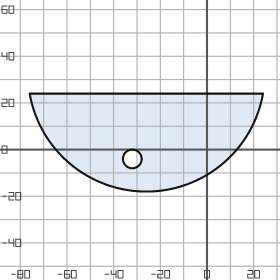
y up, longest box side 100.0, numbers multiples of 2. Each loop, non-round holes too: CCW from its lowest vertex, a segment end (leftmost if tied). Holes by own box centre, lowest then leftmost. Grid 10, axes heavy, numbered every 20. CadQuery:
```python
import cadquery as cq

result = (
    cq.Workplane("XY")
    .moveTo(-76.0, 24.0)
    .threePointArc((-26.0, -18.0), (24.0, 24.0))
    .close()
    .moveTo(-32.0, -4.0)
    .circle(4.0)
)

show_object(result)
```